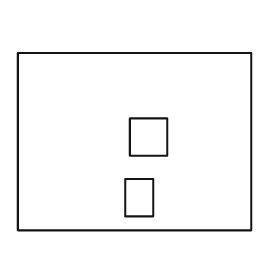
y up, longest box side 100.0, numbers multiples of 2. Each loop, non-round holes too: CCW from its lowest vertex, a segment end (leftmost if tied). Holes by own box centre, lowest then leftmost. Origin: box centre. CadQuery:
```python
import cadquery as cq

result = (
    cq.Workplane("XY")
    .moveTo(-50.0, -38.0)
    .lineTo(50.0, -38.0)
    .lineTo(50.0, 38.0)
    .lineTo(-50.0, 38.0)
    .close()
    .moveTo(-4.0, -32.0)
    .lineTo(8.0, -32.0)
    .lineTo(8.0, -16.0)
    .lineTo(-4.0, -16.0)
    .close()
    .moveTo(-2.0, -6.0)
    .lineTo(14.0, -6.0)
    .lineTo(14.0, 10.0)
    .lineTo(-2.0, 10.0)
    .close()
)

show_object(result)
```